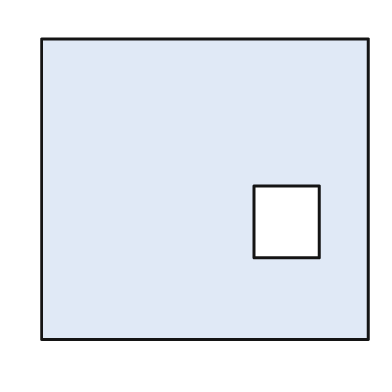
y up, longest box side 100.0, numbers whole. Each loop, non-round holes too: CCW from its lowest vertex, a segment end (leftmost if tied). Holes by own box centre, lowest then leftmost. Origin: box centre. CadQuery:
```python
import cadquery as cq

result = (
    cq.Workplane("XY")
    .moveTo(-50.0, -46.0)
    .lineTo(50.0, -46.0)
    .lineTo(50.0, 46.0)
    .lineTo(-50.0, 46.0)
    .close()
    .moveTo(15.0, -21.0)
    .lineTo(35.0, -21.0)
    .lineTo(35.0, 1.0)
    .lineTo(15.0, 1.0)
    .close()
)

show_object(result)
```